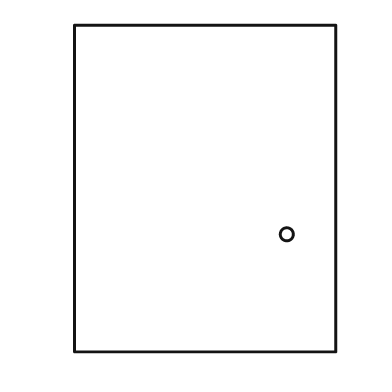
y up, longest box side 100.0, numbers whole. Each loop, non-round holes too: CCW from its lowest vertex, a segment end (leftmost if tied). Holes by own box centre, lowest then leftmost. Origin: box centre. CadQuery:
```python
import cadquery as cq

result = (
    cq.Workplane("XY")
    .moveTo(-40.0, -50.0)
    .lineTo(40.0, -50.0)
    .lineTo(40.0, 50.0)
    .lineTo(-40.0, 50.0)
    .close()
    .moveTo(25.0, -14.0)
    .circle(2.0)
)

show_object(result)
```